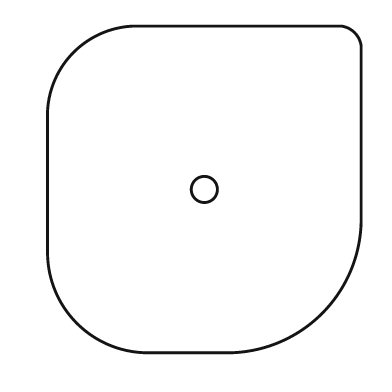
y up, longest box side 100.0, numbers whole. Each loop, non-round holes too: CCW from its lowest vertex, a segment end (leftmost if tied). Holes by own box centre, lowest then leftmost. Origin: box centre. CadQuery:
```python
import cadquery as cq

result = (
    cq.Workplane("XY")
    .moveTo(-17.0, -50.0)
    .lineTo(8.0, -50.0)
    .threePointArc((36.0, -38.0), (48.0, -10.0))
    .lineTo(48.0, 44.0)
    .threePointArc((46.0, 48.0), (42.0, 50.0))
    .lineTo(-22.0, 50.0)
    .threePointArc((-40.0, 42.0), (-48.0, 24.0))
    .lineTo(-48.0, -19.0)
    .threePointArc((-39.0, -41.0), (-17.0, -50.0))
    .close()
    .moveTo(0.0, 0.0)
    .circle(4.0)
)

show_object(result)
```